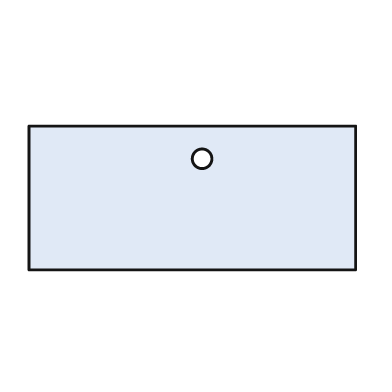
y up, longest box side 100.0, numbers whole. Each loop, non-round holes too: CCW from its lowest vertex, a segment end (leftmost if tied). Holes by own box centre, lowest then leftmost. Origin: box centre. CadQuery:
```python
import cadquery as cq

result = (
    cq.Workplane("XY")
    .moveTo(-50.0, -22.0)
    .lineTo(50.0, -22.0)
    .lineTo(50.0, 22.0)
    .lineTo(-50.0, 22.0)
    .close()
    .moveTo(3.0, 12.0)
    .circle(3.0)
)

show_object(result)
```